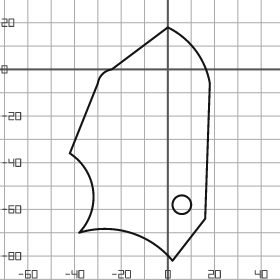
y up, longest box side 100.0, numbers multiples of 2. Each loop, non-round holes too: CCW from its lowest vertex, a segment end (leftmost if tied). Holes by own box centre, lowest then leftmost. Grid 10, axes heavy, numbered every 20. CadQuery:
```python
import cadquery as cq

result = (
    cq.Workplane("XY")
    .moveTo(2.0, -82.0)
    .lineTo(16.0, -64.0)
    .lineTo(18.0, -6.0)
    .threePointArc((12.0, 8.0), (0.0, 18.0))
    .lineTo(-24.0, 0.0)
    .threePointArc((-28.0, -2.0), (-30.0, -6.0))
    .lineTo(-42.0, -36.0)
    .threePointArc((-32.0, -52.0), (-38.0, -70.0))
    .threePointArc((-16.0, -70.0), (2.0, -82.0))
    .close()
    .moveTo(6.0, -58.0)
    .circle(4.0)
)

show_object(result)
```